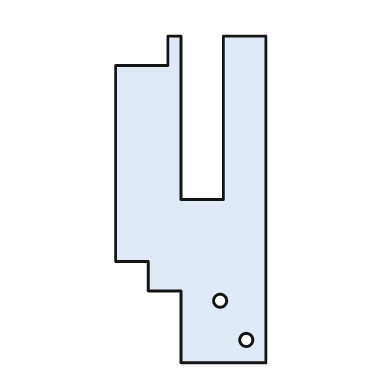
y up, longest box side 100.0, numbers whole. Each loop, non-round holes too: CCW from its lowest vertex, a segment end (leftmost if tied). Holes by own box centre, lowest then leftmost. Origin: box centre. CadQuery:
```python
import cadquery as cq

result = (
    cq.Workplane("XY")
    .moveTo(-3.0, -50.0)
    .lineTo(23.0, -50.0)
    .lineTo(23.0, 50.0)
    .lineTo(10.0, 50.0)
    .lineTo(10.0, 0.0)
    .lineTo(-3.0, 0.0)
    .lineTo(-3.0, 50.0)
    .lineTo(-7.0, 50.0)
    .lineTo(-7.0, 41.0)
    .lineTo(-23.0, 41.0)
    .lineTo(-23.0, -19.0)
    .lineTo(-13.0, -19.0)
    .lineTo(-13.0, -28.0)
    .lineTo(-3.0, -28.0)
    .close()
    .moveTo(17.0, -43.0)
    .circle(2.0)
    .moveTo(9.0, -31.0)
    .circle(2.0)
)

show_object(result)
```